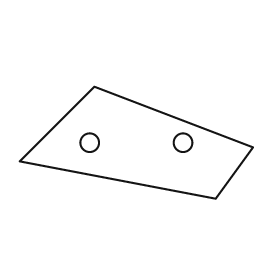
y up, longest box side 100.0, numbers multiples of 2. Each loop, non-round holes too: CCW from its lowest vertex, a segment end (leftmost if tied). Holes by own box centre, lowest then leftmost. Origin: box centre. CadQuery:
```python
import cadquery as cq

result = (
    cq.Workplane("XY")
    .moveTo(34.0, -24.0)
    .lineTo(50.0, -2.0)
    .lineTo(-18.0, 24.0)
    .lineTo(-50.0, -8.0)
    .close()
    .moveTo(-20.0, 0.0)
    .circle(4.0)
    .moveTo(20.0, 0.0)
    .circle(4.0)
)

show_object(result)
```